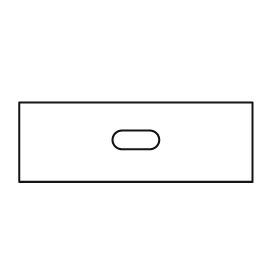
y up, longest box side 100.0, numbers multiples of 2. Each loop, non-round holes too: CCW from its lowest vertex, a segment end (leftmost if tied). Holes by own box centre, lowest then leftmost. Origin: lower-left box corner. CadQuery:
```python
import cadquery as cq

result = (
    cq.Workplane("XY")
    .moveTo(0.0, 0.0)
    .lineTo(100.0, 0.0)
    .lineTo(100.0, 34.0)
    .lineTo(0.0, 34.0)
    .close()
    .moveTo(44.0, 14.0)
    .lineTo(56.0, 14.0)
    .threePointArc((60.0, 18.0), (56.0, 22.0))
    .lineTo(44.0, 22.0)
    .threePointArc((40.0, 18.0), (44.0, 14.0))
    .close()
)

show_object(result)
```